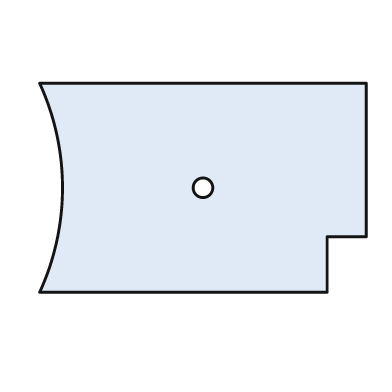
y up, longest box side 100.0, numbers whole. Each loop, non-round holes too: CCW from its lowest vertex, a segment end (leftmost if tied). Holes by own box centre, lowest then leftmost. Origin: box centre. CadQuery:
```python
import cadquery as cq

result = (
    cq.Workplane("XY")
    .moveTo(-50.0, -32.0)
    .lineTo(38.0, -32.0)
    .lineTo(38.0, -15.0)
    .lineTo(50.0, -15.0)
    .lineTo(50.0, 32.0)
    .lineTo(-50.0, 32.0)
    .threePointArc((-43.0, 0.0), (-50.0, -32.0))
    .close()
    .moveTo(0.0, 0.0)
    .circle(3.0)
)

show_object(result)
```